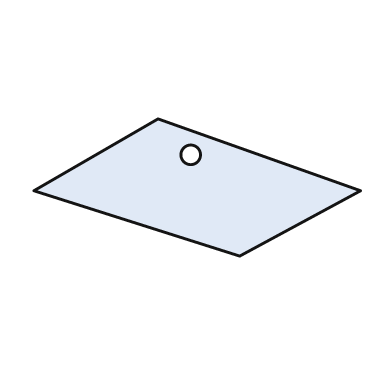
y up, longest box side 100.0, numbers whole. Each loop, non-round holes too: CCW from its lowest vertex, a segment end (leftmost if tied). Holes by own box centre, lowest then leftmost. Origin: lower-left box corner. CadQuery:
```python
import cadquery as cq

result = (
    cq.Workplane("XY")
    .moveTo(63.0, 0.0)
    .lineTo(100.0, 20.0)
    .lineTo(38.0, 42.0)
    .lineTo(0.0, 20.0)
    .close()
    .moveTo(48.0, 31.0)
    .circle(3.0)
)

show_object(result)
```